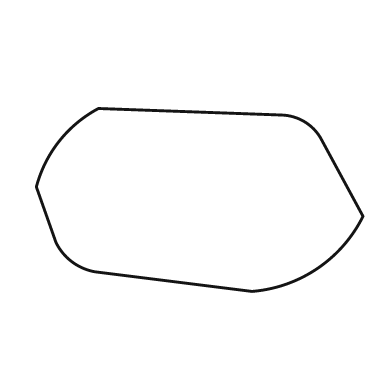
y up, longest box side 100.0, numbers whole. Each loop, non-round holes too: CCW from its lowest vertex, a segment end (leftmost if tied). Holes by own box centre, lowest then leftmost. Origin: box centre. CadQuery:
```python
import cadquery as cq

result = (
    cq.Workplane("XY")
    .moveTo(16.0, -28.0)
    .threePointArc((36.0, -21.0), (50.0, -5.0))
    .lineTo(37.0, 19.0)
    .threePointArc((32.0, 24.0), (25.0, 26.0))
    .lineTo(-31.0, 28.0)
    .threePointArc((-43.0, 18.0), (-50.0, 4.0))
    .lineTo(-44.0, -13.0)
    .threePointArc((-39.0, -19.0), (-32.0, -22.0))
    .close()
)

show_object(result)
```